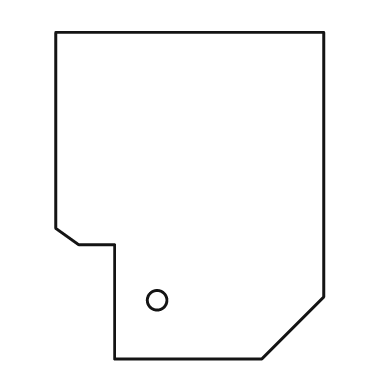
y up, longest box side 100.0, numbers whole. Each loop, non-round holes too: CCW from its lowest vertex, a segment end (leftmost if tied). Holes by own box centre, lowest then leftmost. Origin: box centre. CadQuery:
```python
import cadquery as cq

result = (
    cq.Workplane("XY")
    .moveTo(-23.0, -50.0)
    .lineTo(22.0, -50.0)
    .lineTo(41.0, -31.0)
    .lineTo(41.0, 50.0)
    .lineTo(-41.0, 50.0)
    .lineTo(-41.0, -10.0)
    .lineTo(-34.0, -15.0)
    .lineTo(-23.0, -15.0)
    .close()
    .moveTo(-10.0, -32.0)
    .circle(3.0)
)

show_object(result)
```